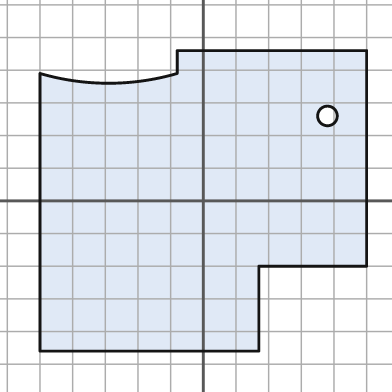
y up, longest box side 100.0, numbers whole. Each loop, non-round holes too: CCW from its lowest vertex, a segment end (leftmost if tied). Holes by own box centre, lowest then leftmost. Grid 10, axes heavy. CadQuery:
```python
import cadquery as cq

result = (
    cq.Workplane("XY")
    .moveTo(-50.0, -46.0)
    .lineTo(17.0, -46.0)
    .lineTo(17.0, -20.0)
    .lineTo(50.0, -20.0)
    .lineTo(50.0, 46.0)
    .lineTo(-8.0, 46.0)
    .lineTo(-8.0, 39.0)
    .threePointArc((-29.0, 36.0), (-50.0, 39.0))
    .close()
    .moveTo(38.0, 26.0)
    .circle(3.0)
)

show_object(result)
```